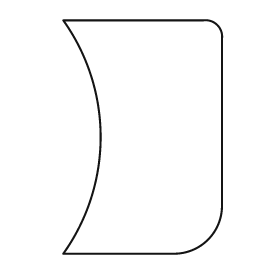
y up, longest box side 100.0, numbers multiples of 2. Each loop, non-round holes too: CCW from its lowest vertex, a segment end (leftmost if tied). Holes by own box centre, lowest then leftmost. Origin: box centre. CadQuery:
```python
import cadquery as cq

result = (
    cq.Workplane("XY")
    .moveTo(-34.0, -50.0)
    .lineTo(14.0, -50.0)
    .threePointArc((28.0, -44.0), (34.0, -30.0))
    .lineTo(34.0, 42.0)
    .threePointArc((32.0, 48.0), (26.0, 50.0))
    .lineTo(-34.0, 50.0)
    .threePointArc((-18.0, 0.0), (-34.0, -50.0))
    .close()
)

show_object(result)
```